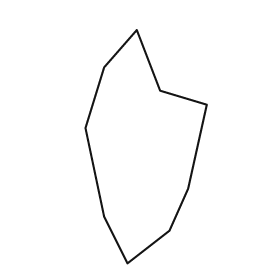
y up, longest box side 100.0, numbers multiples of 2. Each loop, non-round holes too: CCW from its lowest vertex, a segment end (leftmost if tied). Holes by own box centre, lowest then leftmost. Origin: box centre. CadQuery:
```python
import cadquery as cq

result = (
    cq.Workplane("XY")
    .moveTo(-8.0, -50.0)
    .lineTo(10.0, -36.0)
    .lineTo(18.0, -18.0)
    .lineTo(26.0, 18.0)
    .lineTo(6.0, 24.0)
    .lineTo(-4.0, 50.0)
    .lineTo(-18.0, 34.0)
    .lineTo(-26.0, 8.0)
    .lineTo(-18.0, -30.0)
    .close()
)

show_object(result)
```